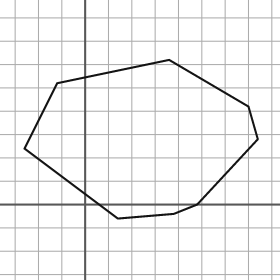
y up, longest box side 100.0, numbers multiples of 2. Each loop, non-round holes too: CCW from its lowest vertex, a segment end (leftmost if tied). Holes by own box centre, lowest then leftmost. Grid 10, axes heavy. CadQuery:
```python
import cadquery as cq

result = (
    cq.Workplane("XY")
    .moveTo(14.0, -6.0)
    .lineTo(38.0, -4.0)
    .lineTo(48.0, 0.0)
    .lineTo(74.0, 28.0)
    .lineTo(70.0, 42.0)
    .lineTo(36.0, 62.0)
    .lineTo(-12.0, 52.0)
    .lineTo(-26.0, 24.0)
    .close()
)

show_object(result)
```